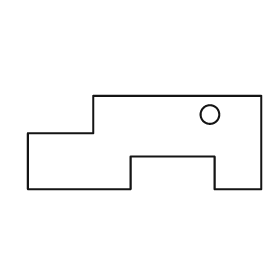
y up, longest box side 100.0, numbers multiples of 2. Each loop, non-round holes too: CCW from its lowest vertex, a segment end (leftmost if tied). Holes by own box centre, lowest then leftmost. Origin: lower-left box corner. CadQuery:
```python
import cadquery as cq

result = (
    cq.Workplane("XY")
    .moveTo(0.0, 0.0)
    .lineTo(44.0, 0.0)
    .lineTo(44.0, 14.0)
    .lineTo(80.0, 14.0)
    .lineTo(80.0, 0.0)
    .lineTo(100.0, 0.0)
    .lineTo(100.0, 40.0)
    .lineTo(28.0, 40.0)
    .lineTo(28.0, 24.0)
    .lineTo(0.0, 24.0)
    .close()
    .moveTo(78.0, 32.0)
    .circle(4.0)
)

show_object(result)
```